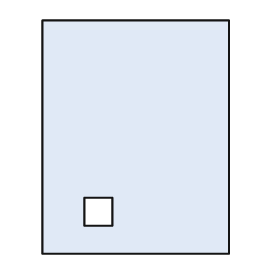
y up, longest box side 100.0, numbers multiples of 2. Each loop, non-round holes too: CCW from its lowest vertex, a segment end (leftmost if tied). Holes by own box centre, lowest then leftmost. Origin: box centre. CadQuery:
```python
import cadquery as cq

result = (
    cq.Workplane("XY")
    .moveTo(-40.0, -50.0)
    .lineTo(40.0, -50.0)
    .lineTo(40.0, 50.0)
    .lineTo(-40.0, 50.0)
    .close()
    .moveTo(-22.0, -38.0)
    .lineTo(-10.0, -38.0)
    .lineTo(-10.0, -26.0)
    .lineTo(-22.0, -26.0)
    .close()
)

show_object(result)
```